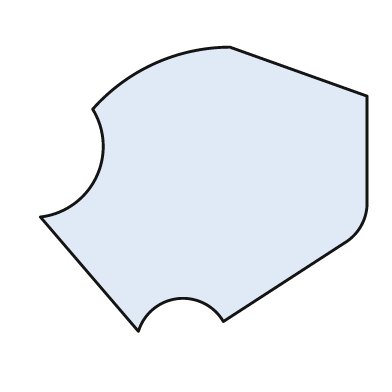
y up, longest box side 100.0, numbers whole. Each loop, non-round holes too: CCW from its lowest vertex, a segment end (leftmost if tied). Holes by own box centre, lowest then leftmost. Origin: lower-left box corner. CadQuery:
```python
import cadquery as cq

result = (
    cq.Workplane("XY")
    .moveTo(30.0, 0.0)
    .threePointArc((42.0, 10.0), (56.0, 3.0))
    .lineTo(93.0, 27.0)
    .threePointArc((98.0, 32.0), (100.0, 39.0))
    .lineTo(100.0, 72.0)
    .lineTo(58.0, 87.0)
    .threePointArc((35.0, 82.0), (16.0, 68.0))
    .threePointArc((17.0, 47.0), (0.0, 35.0))
    .close()
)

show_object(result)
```